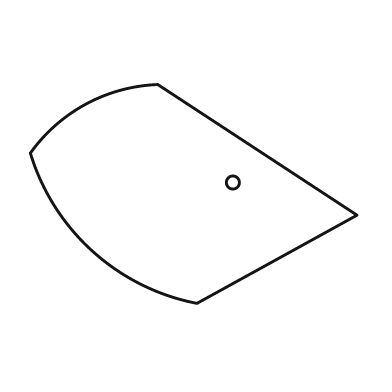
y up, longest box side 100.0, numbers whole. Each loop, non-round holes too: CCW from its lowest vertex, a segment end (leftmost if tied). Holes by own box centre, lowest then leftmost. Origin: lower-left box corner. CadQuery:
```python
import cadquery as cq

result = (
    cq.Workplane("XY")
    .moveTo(51.0, 0.0)
    .lineTo(100.0, 27.0)
    .lineTo(39.0, 67.0)
    .threePointArc((17.0, 61.0), (0.0, 46.0))
    .threePointArc((19.0, 16.0), (51.0, 0.0))
    .close()
    .moveTo(62.0, 37.0)
    .circle(2.0)
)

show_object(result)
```